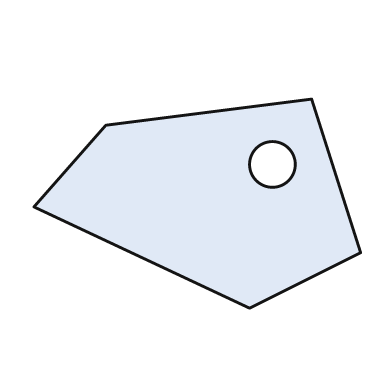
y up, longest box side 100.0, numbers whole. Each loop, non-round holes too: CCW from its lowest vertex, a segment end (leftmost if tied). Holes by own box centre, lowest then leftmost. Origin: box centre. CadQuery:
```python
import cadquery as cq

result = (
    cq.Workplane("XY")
    .moveTo(16.0, -32.0)
    .lineTo(50.0, -15.0)
    .lineTo(35.0, 32.0)
    .lineTo(-28.0, 24.0)
    .lineTo(-50.0, -1.0)
    .close()
    .moveTo(23.0, 12.0)
    .circle(7.0)
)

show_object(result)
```